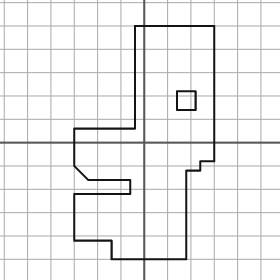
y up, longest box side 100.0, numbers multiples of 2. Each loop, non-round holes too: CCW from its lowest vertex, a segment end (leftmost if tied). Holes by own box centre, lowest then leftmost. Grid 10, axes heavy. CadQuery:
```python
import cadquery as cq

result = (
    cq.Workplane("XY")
    .moveTo(-14.0, -50.0)
    .lineTo(18.0, -50.0)
    .lineTo(18.0, -12.0)
    .lineTo(24.0, -12.0)
    .lineTo(24.0, -8.0)
    .lineTo(30.0, -8.0)
    .lineTo(30.0, 50.0)
    .lineTo(-4.0, 50.0)
    .lineTo(-4.0, 6.0)
    .lineTo(-30.0, 6.0)
    .lineTo(-30.0, -10.0)
    .lineTo(-24.0, -16.0)
    .lineTo(-6.0, -16.0)
    .lineTo(-6.0, -22.0)
    .lineTo(-30.0, -22.0)
    .lineTo(-30.0, -42.0)
    .lineTo(-14.0, -42.0)
    .close()
    .moveTo(14.0, 14.0)
    .lineTo(22.0, 14.0)
    .lineTo(22.0, 22.0)
    .lineTo(14.0, 22.0)
    .close()
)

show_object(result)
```